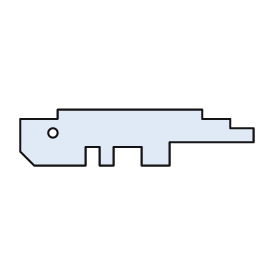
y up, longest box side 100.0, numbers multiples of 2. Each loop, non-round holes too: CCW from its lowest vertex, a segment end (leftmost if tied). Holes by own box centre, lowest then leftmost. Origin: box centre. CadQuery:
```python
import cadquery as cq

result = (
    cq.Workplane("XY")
    .moveTo(-44.0, -12.0)
    .lineTo(-22.0, -12.0)
    .lineTo(-22.0, -4.0)
    .lineTo(-16.0, -4.0)
    .lineTo(-16.0, -12.0)
    .lineTo(-10.0, -12.0)
    .lineTo(-10.0, -4.0)
    .lineTo(2.0, -4.0)
    .lineTo(2.0, -12.0)
    .lineTo(14.0, -12.0)
    .lineTo(14.0, -2.0)
    .lineTo(50.0, -2.0)
    .lineTo(50.0, 4.0)
    .lineTo(40.0, 4.0)
    .lineTo(40.0, 8.0)
    .lineTo(28.0, 8.0)
    .lineTo(28.0, 12.0)
    .lineTo(-34.0, 12.0)
    .lineTo(-34.0, 8.0)
    .lineTo(-50.0, 8.0)
    .lineTo(-50.0, -6.0)
    .close()
    .moveTo(-36.0, 2.0)
    .circle(2.0)
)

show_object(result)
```